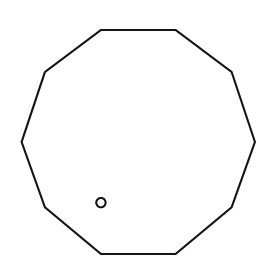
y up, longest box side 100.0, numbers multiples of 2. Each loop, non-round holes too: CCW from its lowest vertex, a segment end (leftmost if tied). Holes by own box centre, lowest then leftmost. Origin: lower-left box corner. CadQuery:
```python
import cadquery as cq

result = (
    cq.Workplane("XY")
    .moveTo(34.0, 0.0)
    .lineTo(66.0, 0.0)
    .lineTo(90.0, 20.0)
    .lineTo(100.0, 48.0)
    .lineTo(90.0, 78.0)
    .lineTo(66.0, 96.0)
    .lineTo(34.0, 96.0)
    .lineTo(10.0, 78.0)
    .lineTo(0.0, 48.0)
    .lineTo(10.0, 20.0)
    .close()
    .moveTo(34.0, 22.0)
    .circle(2.0)
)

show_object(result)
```